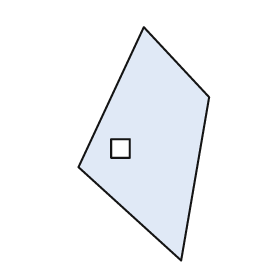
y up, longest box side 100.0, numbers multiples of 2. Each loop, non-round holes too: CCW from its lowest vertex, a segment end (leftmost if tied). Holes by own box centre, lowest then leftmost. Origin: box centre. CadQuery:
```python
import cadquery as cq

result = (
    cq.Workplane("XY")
    .moveTo(16.0, -50.0)
    .lineTo(28.0, 20.0)
    .lineTo(0.0, 50.0)
    .lineTo(-28.0, -10.0)
    .close()
    .moveTo(-14.0, -6.0)
    .lineTo(-6.0, -6.0)
    .lineTo(-6.0, 2.0)
    .lineTo(-14.0, 2.0)
    .close()
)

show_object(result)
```